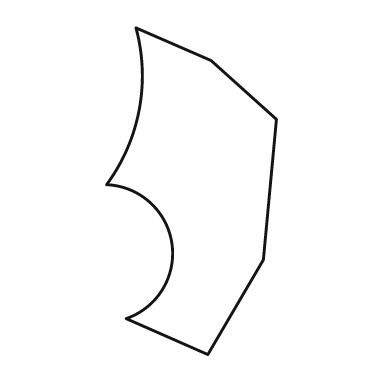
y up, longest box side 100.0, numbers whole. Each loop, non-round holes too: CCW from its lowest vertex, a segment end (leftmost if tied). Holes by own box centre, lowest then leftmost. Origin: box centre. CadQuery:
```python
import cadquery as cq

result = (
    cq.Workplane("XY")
    .moveTo(5.0, -50.0)
    .lineTo(22.0, -21.0)
    .lineTo(26.0, 22.0)
    .lineTo(6.0, 40.0)
    .lineTo(-17.0, 50.0)
    .threePointArc((-16.0, 25.0), (-26.0, 2.0))
    .threePointArc((-6.0, -16.0), (-20.0, -39.0))
    .close()
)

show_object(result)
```